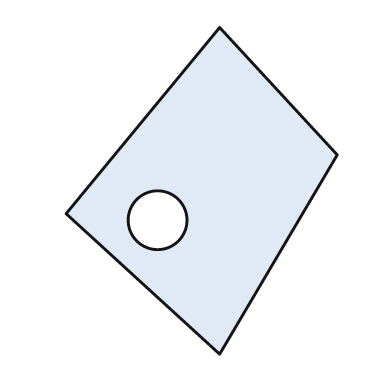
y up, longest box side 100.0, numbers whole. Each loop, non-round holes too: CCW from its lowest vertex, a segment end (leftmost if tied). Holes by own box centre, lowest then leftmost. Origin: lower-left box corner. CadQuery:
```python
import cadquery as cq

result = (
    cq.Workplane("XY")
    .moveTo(47.0, 0.0)
    .lineTo(83.0, 61.0)
    .lineTo(47.0, 100.0)
    .lineTo(0.0, 43.0)
    .close()
    .moveTo(28.0, 41.0)
    .circle(9.0)
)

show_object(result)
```